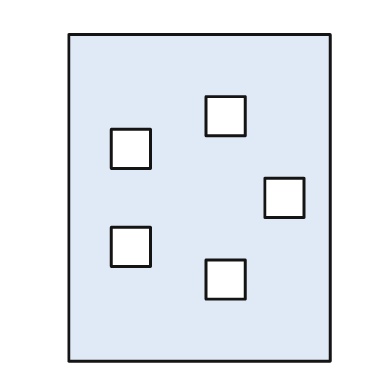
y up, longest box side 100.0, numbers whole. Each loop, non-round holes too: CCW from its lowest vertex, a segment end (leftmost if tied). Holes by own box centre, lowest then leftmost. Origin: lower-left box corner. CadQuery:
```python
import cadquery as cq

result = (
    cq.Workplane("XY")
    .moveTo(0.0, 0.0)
    .lineTo(80.0, 0.0)
    .lineTo(80.0, 100.0)
    .lineTo(0.0, 100.0)
    .close()
    .moveTo(42.0, 19.0)
    .lineTo(54.0, 19.0)
    .lineTo(54.0, 31.0)
    .lineTo(42.0, 31.0)
    .close()
    .moveTo(13.0, 29.0)
    .lineTo(25.0, 29.0)
    .lineTo(25.0, 41.0)
    .lineTo(13.0, 41.0)
    .close()
    .moveTo(60.0, 44.0)
    .lineTo(72.0, 44.0)
    .lineTo(72.0, 56.0)
    .lineTo(60.0, 56.0)
    .close()
    .moveTo(13.0, 59.0)
    .lineTo(25.0, 59.0)
    .lineTo(25.0, 71.0)
    .lineTo(13.0, 71.0)
    .close()
    .moveTo(42.0, 69.0)
    .lineTo(54.0, 69.0)
    .lineTo(54.0, 81.0)
    .lineTo(42.0, 81.0)
    .close()
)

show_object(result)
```